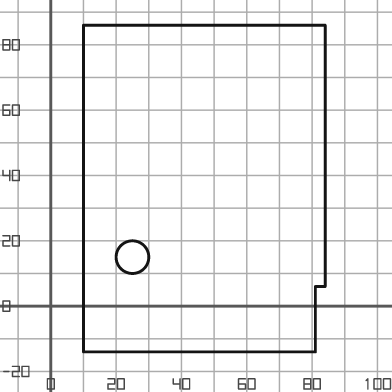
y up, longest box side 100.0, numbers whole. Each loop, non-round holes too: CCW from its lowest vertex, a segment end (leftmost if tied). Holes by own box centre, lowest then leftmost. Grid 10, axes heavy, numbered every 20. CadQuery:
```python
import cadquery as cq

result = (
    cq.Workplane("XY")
    .moveTo(10.0, -14.0)
    .lineTo(81.0, -14.0)
    .lineTo(81.0, 6.0)
    .lineTo(84.0, 6.0)
    .lineTo(84.0, 86.0)
    .lineTo(10.0, 86.0)
    .close()
    .moveTo(25.0, 15.0)
    .circle(5.0)
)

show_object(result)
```